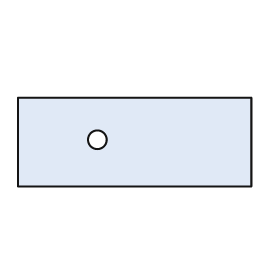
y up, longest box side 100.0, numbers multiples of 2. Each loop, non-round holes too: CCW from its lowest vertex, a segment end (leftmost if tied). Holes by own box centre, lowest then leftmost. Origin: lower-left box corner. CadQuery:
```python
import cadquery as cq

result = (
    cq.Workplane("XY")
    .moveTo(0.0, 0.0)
    .lineTo(100.0, 0.0)
    .lineTo(100.0, 38.0)
    .lineTo(0.0, 38.0)
    .close()
    .moveTo(34.0, 20.0)
    .circle(4.0)
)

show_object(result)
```